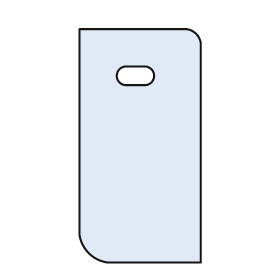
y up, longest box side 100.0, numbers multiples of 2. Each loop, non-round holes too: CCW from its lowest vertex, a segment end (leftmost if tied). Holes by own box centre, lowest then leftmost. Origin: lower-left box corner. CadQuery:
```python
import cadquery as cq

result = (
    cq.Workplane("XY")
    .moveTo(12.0, 0.0)
    .lineTo(52.0, 0.0)
    .lineTo(52.0, 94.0)
    .threePointArc((50.0, 98.0), (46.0, 100.0))
    .lineTo(0.0, 100.0)
    .lineTo(0.0, 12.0)
    .threePointArc((4.0, 4.0), (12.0, 0.0))
    .close()
    .moveTo(20.0, 76.0)
    .lineTo(28.0, 76.0)
    .threePointArc((32.0, 80.0), (28.0, 84.0))
    .lineTo(20.0, 84.0)
    .threePointArc((16.0, 80.0), (20.0, 76.0))
    .close()
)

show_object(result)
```